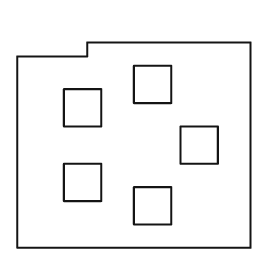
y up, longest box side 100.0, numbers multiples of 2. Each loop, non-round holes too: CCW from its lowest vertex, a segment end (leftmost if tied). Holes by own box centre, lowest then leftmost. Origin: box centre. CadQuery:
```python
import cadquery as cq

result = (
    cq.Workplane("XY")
    .moveTo(-50.0, -44.0)
    .lineTo(50.0, -44.0)
    .lineTo(50.0, 44.0)
    .lineTo(-20.0, 44.0)
    .lineTo(-20.0, 38.0)
    .lineTo(-50.0, 38.0)
    .close()
    .moveTo(0.0, -34.0)
    .lineTo(16.0, -34.0)
    .lineTo(16.0, -18.0)
    .lineTo(0.0, -18.0)
    .close()
    .moveTo(-30.0, -24.0)
    .lineTo(-14.0, -24.0)
    .lineTo(-14.0, -8.0)
    .lineTo(-30.0, -8.0)
    .close()
    .moveTo(20.0, -8.0)
    .lineTo(36.0, -8.0)
    .lineTo(36.0, 8.0)
    .lineTo(20.0, 8.0)
    .close()
    .moveTo(-30.0, 8.0)
    .lineTo(-14.0, 8.0)
    .lineTo(-14.0, 24.0)
    .lineTo(-30.0, 24.0)
    .close()
    .moveTo(0.0, 18.0)
    .lineTo(16.0, 18.0)
    .lineTo(16.0, 34.0)
    .lineTo(0.0, 34.0)
    .close()
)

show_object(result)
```